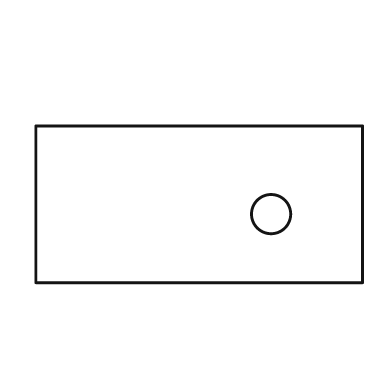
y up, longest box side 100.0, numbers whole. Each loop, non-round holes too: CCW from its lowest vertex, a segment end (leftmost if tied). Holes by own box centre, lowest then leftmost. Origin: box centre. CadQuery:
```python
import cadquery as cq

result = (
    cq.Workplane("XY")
    .moveTo(-50.0, -24.0)
    .lineTo(50.0, -24.0)
    .lineTo(50.0, 24.0)
    .lineTo(-50.0, 24.0)
    .close()
    .moveTo(22.0, -3.0)
    .circle(6.0)
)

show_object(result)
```